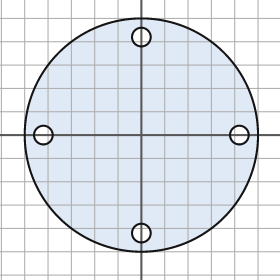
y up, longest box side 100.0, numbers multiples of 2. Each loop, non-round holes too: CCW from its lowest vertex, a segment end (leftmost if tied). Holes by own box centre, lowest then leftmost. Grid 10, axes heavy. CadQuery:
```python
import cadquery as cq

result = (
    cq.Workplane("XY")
    .moveTo(0.0, 0.0)
    .circle(50.0)
    .moveTo(0.0, -42.0)
    .circle(4.0)
    .moveTo(-42.0, 0.0)
    .circle(4.0)
    .moveTo(42.0, 0.0)
    .circle(4.0)
    .moveTo(0.0, 42.0)
    .circle(4.0)
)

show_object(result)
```